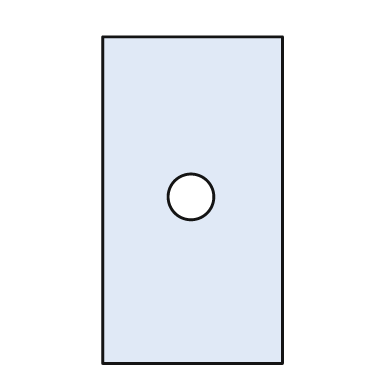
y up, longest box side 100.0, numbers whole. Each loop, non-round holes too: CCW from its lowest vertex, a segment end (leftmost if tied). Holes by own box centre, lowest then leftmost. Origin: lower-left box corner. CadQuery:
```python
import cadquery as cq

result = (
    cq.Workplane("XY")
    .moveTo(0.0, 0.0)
    .lineTo(55.0, 0.0)
    .lineTo(55.0, 100.0)
    .lineTo(0.0, 100.0)
    .close()
    .moveTo(27.0, 51.0)
    .circle(7.0)
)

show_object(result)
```